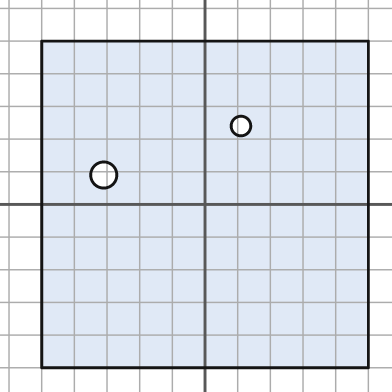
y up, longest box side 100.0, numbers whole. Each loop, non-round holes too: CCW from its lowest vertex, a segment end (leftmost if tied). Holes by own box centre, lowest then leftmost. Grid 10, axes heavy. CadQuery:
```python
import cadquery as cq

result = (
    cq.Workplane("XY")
    .moveTo(-50.0, -50.0)
    .lineTo(50.0, -50.0)
    .lineTo(50.0, 50.0)
    .lineTo(-50.0, 50.0)
    .close()
    .moveTo(-31.0, 9.0)
    .circle(4.0)
    .moveTo(11.0, 24.0)
    .circle(3.0)
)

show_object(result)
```